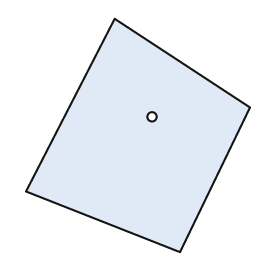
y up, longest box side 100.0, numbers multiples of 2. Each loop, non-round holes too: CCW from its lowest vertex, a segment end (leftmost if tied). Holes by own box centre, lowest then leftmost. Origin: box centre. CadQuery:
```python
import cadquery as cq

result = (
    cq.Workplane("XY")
    .moveTo(18.0, -50.0)
    .lineTo(48.0, 12.0)
    .lineTo(-10.0, 50.0)
    .lineTo(-48.0, -24.0)
    .close()
    .moveTo(6.0, 8.0)
    .circle(2.0)
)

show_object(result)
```